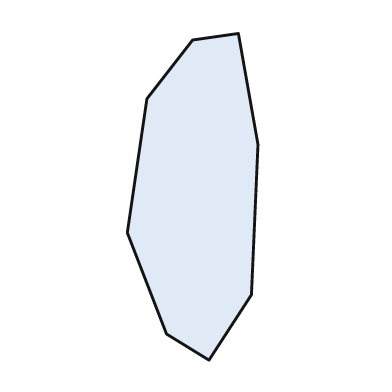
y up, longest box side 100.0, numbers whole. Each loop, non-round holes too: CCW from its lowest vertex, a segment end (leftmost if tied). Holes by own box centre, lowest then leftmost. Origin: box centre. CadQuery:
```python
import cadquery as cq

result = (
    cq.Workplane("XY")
    .moveTo(5.0, -50.0)
    .lineTo(18.0, -30.0)
    .lineTo(20.0, 16.0)
    .lineTo(14.0, 50.0)
    .lineTo(0.0, 48.0)
    .lineTo(-14.0, 30.0)
    .lineTo(-20.0, -11.0)
    .lineTo(-8.0, -42.0)
    .close()
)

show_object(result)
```